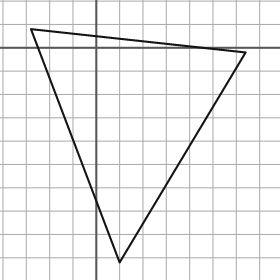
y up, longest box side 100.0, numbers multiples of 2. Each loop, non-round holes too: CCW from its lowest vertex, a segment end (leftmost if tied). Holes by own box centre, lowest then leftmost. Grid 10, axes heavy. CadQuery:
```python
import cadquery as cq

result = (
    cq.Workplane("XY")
    .moveTo(10.0, -92.0)
    .lineTo(64.0, -2.0)
    .lineTo(-28.0, 8.0)
    .close()
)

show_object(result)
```